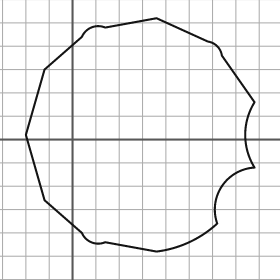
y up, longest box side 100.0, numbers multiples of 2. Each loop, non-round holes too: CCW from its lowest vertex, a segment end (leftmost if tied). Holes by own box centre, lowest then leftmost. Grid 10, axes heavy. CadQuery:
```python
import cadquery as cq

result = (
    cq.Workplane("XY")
    .moveTo(36.0, -48.0)
    .threePointArc((50.0, -44.0), (62.0, -36.0))
    .threePointArc((64.0, -20.0), (78.0, -12.0))
    .threePointArc((74.0, 2.0), (78.0, 16.0))
    .lineTo(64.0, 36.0)
    .threePointArc((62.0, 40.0), (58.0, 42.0))
    .lineTo(36.0, 52.0)
    .lineTo(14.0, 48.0)
    .threePointArc((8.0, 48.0), (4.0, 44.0))
    .lineTo(-12.0, 30.0)
    .lineTo(-20.0, 2.0)
    .lineTo(-12.0, -26.0)
    .lineTo(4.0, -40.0)
    .threePointArc((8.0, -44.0), (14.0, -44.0))
    .close()
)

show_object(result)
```